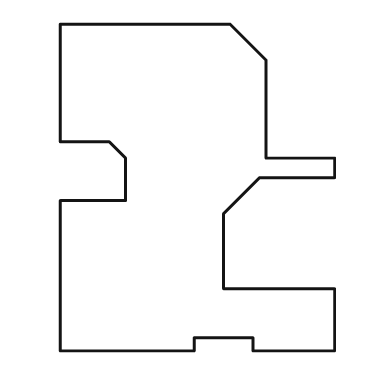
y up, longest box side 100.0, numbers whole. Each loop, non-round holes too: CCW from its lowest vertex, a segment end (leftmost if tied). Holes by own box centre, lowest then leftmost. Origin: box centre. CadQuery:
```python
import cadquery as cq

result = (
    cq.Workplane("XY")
    .moveTo(-42.0, -50.0)
    .lineTo(-1.0, -50.0)
    .lineTo(-1.0, -46.0)
    .lineTo(17.0, -46.0)
    .lineTo(17.0, -50.0)
    .lineTo(42.0, -50.0)
    .lineTo(42.0, -31.0)
    .lineTo(8.0, -31.0)
    .lineTo(8.0, -8.0)
    .lineTo(19.0, 3.0)
    .lineTo(42.0, 3.0)
    .lineTo(42.0, 9.0)
    .lineTo(21.0, 9.0)
    .lineTo(21.0, 39.0)
    .lineTo(10.0, 50.0)
    .lineTo(-42.0, 50.0)
    .lineTo(-42.0, 14.0)
    .lineTo(-27.0, 14.0)
    .lineTo(-22.0, 9.0)
    .lineTo(-22.0, -4.0)
    .lineTo(-42.0, -4.0)
    .close()
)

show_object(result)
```